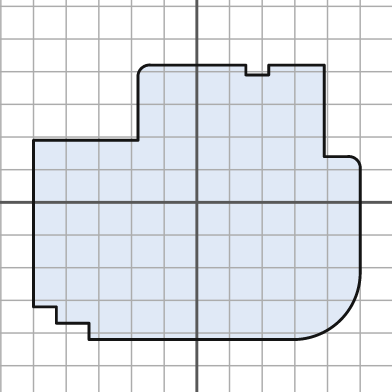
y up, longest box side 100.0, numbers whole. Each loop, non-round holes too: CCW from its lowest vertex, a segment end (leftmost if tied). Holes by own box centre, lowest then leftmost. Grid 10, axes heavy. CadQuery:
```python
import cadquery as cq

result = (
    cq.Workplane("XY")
    .moveTo(-33.0, -42.0)
    .lineTo(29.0, -42.0)
    .threePointArc((44.0, -36.0), (50.0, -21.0))
    .lineTo(50.0, 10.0)
    .threePointArc((49.0, 13.0), (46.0, 14.0))
    .lineTo(39.0, 14.0)
    .lineTo(39.0, 42.0)
    .lineTo(22.0, 42.0)
    .lineTo(22.0, 39.0)
    .lineTo(15.0, 39.0)
    .lineTo(15.0, 42.0)
    .lineTo(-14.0, 42.0)
    .threePointArc((-17.0, 41.0), (-18.0, 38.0))
    .lineTo(-18.0, 19.0)
    .lineTo(-50.0, 19.0)
    .lineTo(-50.0, -32.0)
    .lineTo(-43.0, -32.0)
    .lineTo(-43.0, -37.0)
    .lineTo(-33.0, -37.0)
    .close()
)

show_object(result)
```